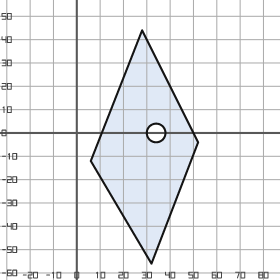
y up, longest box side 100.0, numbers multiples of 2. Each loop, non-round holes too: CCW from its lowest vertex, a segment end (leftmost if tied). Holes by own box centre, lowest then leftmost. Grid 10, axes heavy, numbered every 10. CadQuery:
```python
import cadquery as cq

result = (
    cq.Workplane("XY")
    .moveTo(32.0, -56.0)
    .lineTo(52.0, -4.0)
    .lineTo(28.0, 44.0)
    .lineTo(6.0, -12.0)
    .close()
    .moveTo(34.0, 0.0)
    .circle(4.0)
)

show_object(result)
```